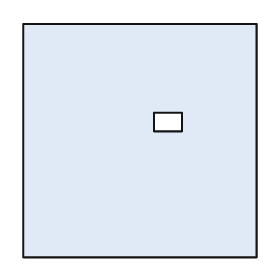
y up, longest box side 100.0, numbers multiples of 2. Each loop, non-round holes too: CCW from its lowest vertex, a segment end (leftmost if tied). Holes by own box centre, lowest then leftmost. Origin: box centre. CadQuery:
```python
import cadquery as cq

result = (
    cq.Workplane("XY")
    .moveTo(-50.0, -50.0)
    .lineTo(50.0, -50.0)
    .lineTo(50.0, 50.0)
    .lineTo(-50.0, 50.0)
    .close()
    .moveTo(6.0, 4.0)
    .lineTo(18.0, 4.0)
    .lineTo(18.0, 12.0)
    .lineTo(6.0, 12.0)
    .close()
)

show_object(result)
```